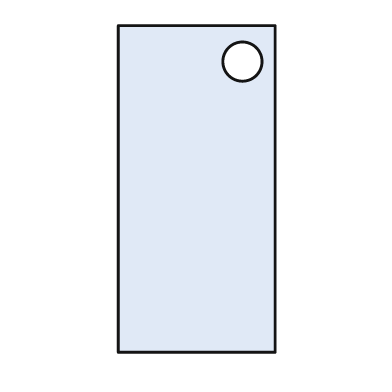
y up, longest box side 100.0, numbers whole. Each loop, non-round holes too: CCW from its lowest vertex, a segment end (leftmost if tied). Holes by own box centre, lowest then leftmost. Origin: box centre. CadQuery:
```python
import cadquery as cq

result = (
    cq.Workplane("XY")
    .moveTo(-24.0, -50.0)
    .lineTo(24.0, -50.0)
    .lineTo(24.0, 50.0)
    .lineTo(-24.0, 50.0)
    .close()
    .moveTo(14.0, 39.0)
    .circle(6.0)
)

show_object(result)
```